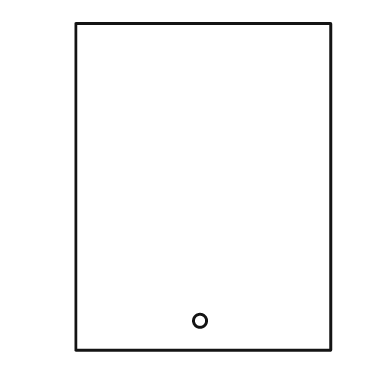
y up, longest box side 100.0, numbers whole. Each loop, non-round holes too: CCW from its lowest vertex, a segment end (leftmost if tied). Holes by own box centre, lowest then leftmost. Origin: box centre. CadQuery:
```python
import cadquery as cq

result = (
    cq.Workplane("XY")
    .moveTo(-39.0, -50.0)
    .lineTo(39.0, -50.0)
    .lineTo(39.0, 50.0)
    .lineTo(-39.0, 50.0)
    .close()
    .moveTo(-1.0, -41.0)
    .circle(2.0)
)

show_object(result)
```